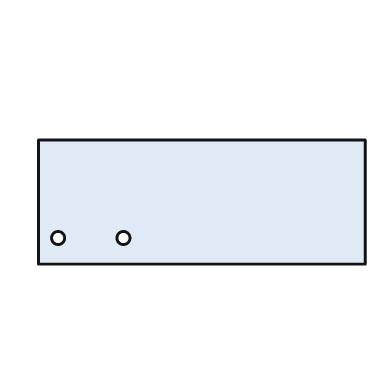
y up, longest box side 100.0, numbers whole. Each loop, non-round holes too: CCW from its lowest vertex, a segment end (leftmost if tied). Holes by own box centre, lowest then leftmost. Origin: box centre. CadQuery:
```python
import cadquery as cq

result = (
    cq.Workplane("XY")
    .moveTo(-50.0, -19.0)
    .lineTo(50.0, -19.0)
    .lineTo(50.0, 19.0)
    .lineTo(-50.0, 19.0)
    .close()
    .moveTo(-44.0, -11.0)
    .circle(2.0)
    .moveTo(-24.0, -11.0)
    .circle(2.0)
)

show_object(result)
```